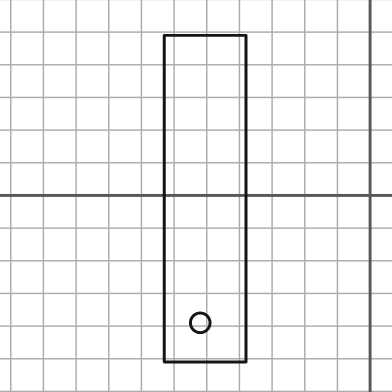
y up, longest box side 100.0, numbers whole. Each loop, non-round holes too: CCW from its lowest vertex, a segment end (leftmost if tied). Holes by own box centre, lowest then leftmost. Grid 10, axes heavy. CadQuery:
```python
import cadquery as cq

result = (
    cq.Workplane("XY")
    .moveTo(-63.0, -51.0)
    .lineTo(-38.0, -51.0)
    .lineTo(-38.0, 49.0)
    .lineTo(-63.0, 49.0)
    .close()
    .moveTo(-52.0, -39.0)
    .circle(3.0)
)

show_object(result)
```